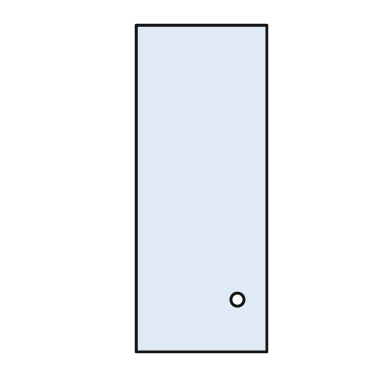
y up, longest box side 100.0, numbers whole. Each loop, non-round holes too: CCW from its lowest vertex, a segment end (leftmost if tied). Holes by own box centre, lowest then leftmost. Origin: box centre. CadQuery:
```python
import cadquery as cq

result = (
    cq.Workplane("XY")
    .moveTo(-20.0, -50.0)
    .lineTo(20.0, -50.0)
    .lineTo(20.0, 50.0)
    .lineTo(-20.0, 50.0)
    .close()
    .moveTo(11.0, -34.0)
    .circle(2.0)
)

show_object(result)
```